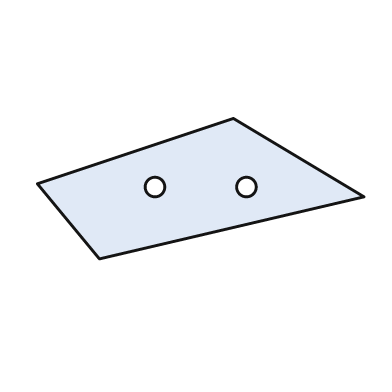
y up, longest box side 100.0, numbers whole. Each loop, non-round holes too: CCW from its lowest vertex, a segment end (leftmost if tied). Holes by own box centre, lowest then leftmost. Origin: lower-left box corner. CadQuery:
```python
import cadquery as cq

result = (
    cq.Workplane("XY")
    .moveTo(19.0, 0.0)
    .lineTo(100.0, 19.0)
    .lineTo(60.0, 43.0)
    .lineTo(0.0, 23.0)
    .close()
    .moveTo(36.0, 22.0)
    .circle(3.0)
    .moveTo(64.0, 22.0)
    .circle(3.0)
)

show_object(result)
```